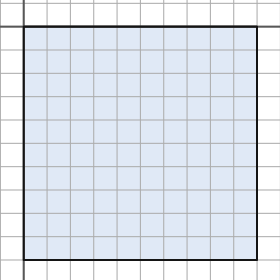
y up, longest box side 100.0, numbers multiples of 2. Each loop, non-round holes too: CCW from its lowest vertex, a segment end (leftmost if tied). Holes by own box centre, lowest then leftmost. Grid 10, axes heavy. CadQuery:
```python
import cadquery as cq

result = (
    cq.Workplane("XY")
    .moveTo(0.0, -100.0)
    .lineTo(100.0, -100.0)
    .lineTo(100.0, 0.0)
    .lineTo(0.0, 0.0)
    .close()
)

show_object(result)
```